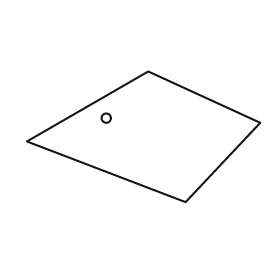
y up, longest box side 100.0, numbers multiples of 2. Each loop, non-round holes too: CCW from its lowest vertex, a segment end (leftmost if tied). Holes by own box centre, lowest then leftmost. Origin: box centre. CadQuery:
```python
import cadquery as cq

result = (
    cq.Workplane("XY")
    .moveTo(18.0, -28.0)
    .lineTo(50.0, 6.0)
    .lineTo(2.0, 28.0)
    .lineTo(-50.0, -2.0)
    .close()
    .moveTo(-16.0, 8.0)
    .circle(2.0)
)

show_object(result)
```